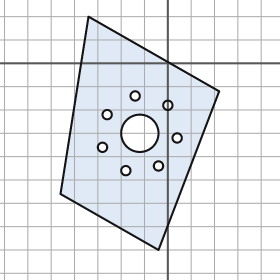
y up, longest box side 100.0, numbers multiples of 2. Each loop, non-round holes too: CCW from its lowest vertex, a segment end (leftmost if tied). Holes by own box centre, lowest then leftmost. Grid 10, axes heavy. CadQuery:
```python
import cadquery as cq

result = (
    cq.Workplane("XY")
    .moveTo(-4.0, -80.0)
    .lineTo(22.0, -12.0)
    .lineTo(-34.0, 20.0)
    .lineTo(-46.0, -56.0)
    .close()
    .moveTo(-18.0, -46.0)
    .circle(2.0)
    .moveTo(-4.0, -44.0)
    .circle(2.0)
    .moveTo(-28.0, -36.0)
    .circle(2.0)
    .moveTo(4.0, -32.0)
    .circle(2.0)
    .moveTo(-12.0, -30.0)
    .circle(8.0)
    .moveTo(-26.0, -22.0)
    .circle(2.0)
    .moveTo(0.0, -18.0)
    .circle(2.0)
    .moveTo(-14.0, -14.0)
    .circle(2.0)
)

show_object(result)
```